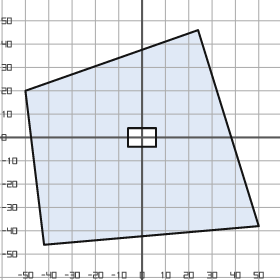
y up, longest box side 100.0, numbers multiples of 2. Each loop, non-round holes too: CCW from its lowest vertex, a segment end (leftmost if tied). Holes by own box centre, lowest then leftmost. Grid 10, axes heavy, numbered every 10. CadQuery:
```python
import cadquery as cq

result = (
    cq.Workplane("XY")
    .moveTo(-42.0, -46.0)
    .lineTo(50.0, -38.0)
    .lineTo(24.0, 46.0)
    .lineTo(-50.0, 20.0)
    .close()
    .moveTo(-6.0, -4.0)
    .lineTo(6.0, -4.0)
    .lineTo(6.0, 4.0)
    .lineTo(-6.0, 4.0)
    .close()
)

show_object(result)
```